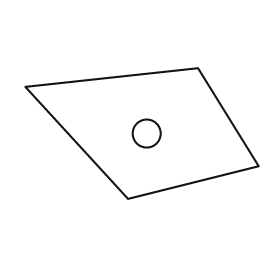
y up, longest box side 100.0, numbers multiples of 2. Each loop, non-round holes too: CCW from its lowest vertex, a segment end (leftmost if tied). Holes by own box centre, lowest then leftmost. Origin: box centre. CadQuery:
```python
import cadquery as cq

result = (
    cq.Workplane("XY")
    .moveTo(-6.0, -28.0)
    .lineTo(50.0, -14.0)
    .lineTo(24.0, 28.0)
    .lineTo(-50.0, 20.0)
    .close()
    .moveTo(2.0, 0.0)
    .circle(6.0)
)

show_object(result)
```